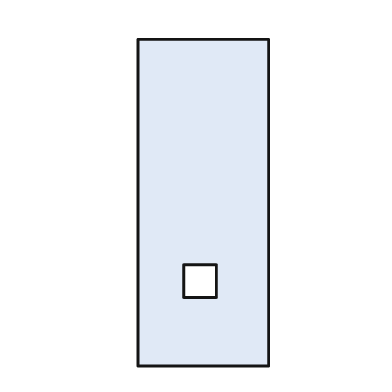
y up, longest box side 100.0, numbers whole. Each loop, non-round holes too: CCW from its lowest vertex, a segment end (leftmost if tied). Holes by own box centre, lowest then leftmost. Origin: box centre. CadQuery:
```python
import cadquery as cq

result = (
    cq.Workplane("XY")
    .moveTo(-20.0, -50.0)
    .lineTo(20.0, -50.0)
    .lineTo(20.0, 50.0)
    .lineTo(-20.0, 50.0)
    .close()
    .moveTo(-6.0, -29.0)
    .lineTo(4.0, -29.0)
    .lineTo(4.0, -19.0)
    .lineTo(-6.0, -19.0)
    .close()
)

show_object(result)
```